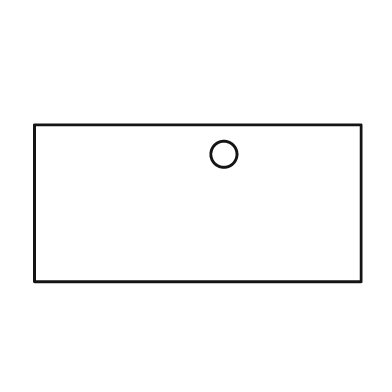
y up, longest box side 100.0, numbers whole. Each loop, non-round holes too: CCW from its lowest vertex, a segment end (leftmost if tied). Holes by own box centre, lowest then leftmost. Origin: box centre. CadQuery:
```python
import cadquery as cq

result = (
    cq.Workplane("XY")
    .moveTo(-50.0, -24.0)
    .lineTo(50.0, -24.0)
    .lineTo(50.0, 24.0)
    .lineTo(-50.0, 24.0)
    .close()
    .moveTo(8.0, 15.0)
    .circle(4.0)
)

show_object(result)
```